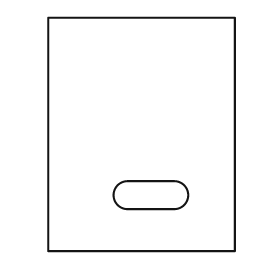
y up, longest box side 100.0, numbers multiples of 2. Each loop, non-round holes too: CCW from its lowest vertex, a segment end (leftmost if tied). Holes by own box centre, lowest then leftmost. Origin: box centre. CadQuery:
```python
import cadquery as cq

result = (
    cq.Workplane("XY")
    .moveTo(-40.0, -50.0)
    .lineTo(40.0, -50.0)
    .lineTo(40.0, 50.0)
    .lineTo(-40.0, 50.0)
    .close()
    .moveTo(-6.0, -32.0)
    .lineTo(14.0, -32.0)
    .threePointArc((20.0, -26.0), (14.0, -20.0))
    .lineTo(-6.0, -20.0)
    .threePointArc((-12.0, -26.0), (-6.0, -32.0))
    .close()
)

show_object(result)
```